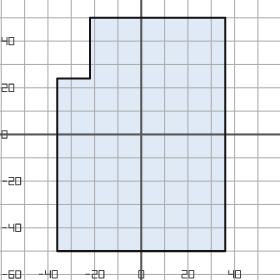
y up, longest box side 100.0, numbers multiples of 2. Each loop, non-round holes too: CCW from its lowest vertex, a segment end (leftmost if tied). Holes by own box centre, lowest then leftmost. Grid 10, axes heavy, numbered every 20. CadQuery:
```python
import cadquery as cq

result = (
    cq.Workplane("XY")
    .moveTo(-36.0, -50.0)
    .lineTo(36.0, -50.0)
    .lineTo(36.0, 50.0)
    .lineTo(-22.0, 50.0)
    .lineTo(-22.0, 24.0)
    .lineTo(-36.0, 24.0)
    .close()
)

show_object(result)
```